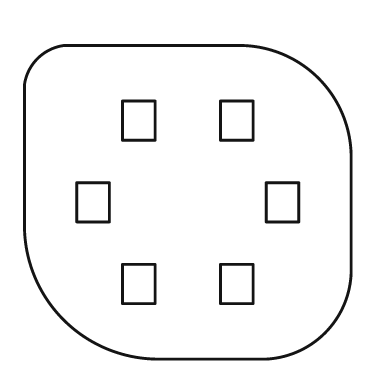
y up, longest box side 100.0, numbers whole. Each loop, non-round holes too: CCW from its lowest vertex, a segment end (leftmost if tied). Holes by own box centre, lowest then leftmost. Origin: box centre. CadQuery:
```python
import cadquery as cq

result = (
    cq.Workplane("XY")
    .moveTo(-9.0, -48.0)
    .lineTo(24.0, -48.0)
    .threePointArc((42.0, -40.0), (50.0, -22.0))
    .lineTo(50.0, 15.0)
    .threePointArc((40.0, 38.0), (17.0, 48.0))
    .lineTo(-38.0, 48.0)
    .threePointArc((-46.0, 44.0), (-50.0, 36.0))
    .lineTo(-50.0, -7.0)
    .threePointArc((-38.0, -36.0), (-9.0, -48.0))
    .close()
    .moveTo(-20.0, -31.0)
    .lineTo(-10.0, -31.0)
    .lineTo(-10.0, -19.0)
    .lineTo(-20.0, -19.0)
    .close()
    .moveTo(10.0, -31.0)
    .lineTo(20.0, -31.0)
    .lineTo(20.0, -19.0)
    .lineTo(10.0, -19.0)
    .close()
    .moveTo(-34.0, -6.0)
    .lineTo(-24.0, -6.0)
    .lineTo(-24.0, 6.0)
    .lineTo(-34.0, 6.0)
    .close()
    .moveTo(24.0, -6.0)
    .lineTo(34.0, -6.0)
    .lineTo(34.0, 6.0)
    .lineTo(24.0, 6.0)
    .close()
    .moveTo(-20.0, 19.0)
    .lineTo(-10.0, 19.0)
    .lineTo(-10.0, 31.0)
    .lineTo(-20.0, 31.0)
    .close()
    .moveTo(10.0, 19.0)
    .lineTo(20.0, 19.0)
    .lineTo(20.0, 31.0)
    .lineTo(10.0, 31.0)
    .close()
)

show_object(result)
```